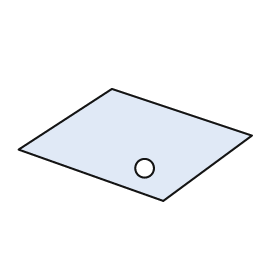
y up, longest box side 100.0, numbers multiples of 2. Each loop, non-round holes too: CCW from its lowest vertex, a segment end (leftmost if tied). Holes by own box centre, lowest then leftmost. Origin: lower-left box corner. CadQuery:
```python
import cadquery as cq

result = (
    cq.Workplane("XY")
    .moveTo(62.0, 0.0)
    .lineTo(100.0, 28.0)
    .lineTo(40.0, 48.0)
    .lineTo(0.0, 22.0)
    .close()
    .moveTo(54.0, 14.0)
    .circle(4.0)
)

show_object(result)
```